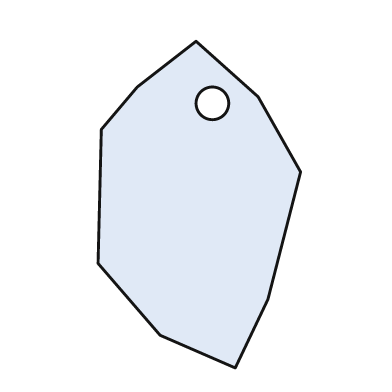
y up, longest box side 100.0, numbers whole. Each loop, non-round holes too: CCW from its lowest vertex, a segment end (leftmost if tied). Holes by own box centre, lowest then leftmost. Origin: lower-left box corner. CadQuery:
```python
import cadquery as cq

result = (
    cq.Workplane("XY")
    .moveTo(42.0, 0.0)
    .lineTo(52.0, 21.0)
    .lineTo(62.0, 60.0)
    .lineTo(49.0, 83.0)
    .lineTo(30.0, 100.0)
    .lineTo(12.0, 86.0)
    .lineTo(1.0, 73.0)
    .lineTo(0.0, 32.0)
    .lineTo(19.0, 10.0)
    .close()
    .moveTo(35.0, 81.0)
    .circle(5.0)
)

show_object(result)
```